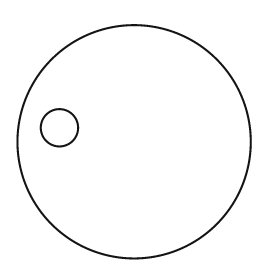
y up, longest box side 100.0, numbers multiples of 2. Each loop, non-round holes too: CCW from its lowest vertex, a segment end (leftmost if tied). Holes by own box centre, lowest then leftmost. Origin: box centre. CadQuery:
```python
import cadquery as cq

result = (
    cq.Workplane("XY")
    .moveTo(0.0, 0.0)
    .circle(50.0)
    .moveTo(-32.0, 6.0)
    .circle(8.0)
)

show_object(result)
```